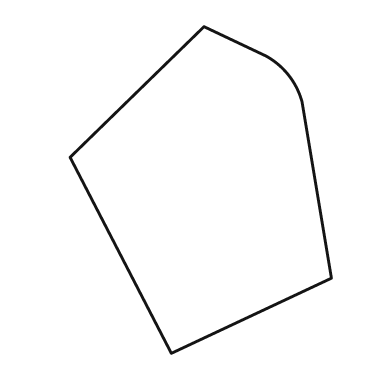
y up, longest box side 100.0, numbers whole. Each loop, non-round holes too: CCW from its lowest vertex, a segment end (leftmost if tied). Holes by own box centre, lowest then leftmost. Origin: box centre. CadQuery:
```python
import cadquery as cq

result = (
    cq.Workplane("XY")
    .moveTo(-9.0, -50.0)
    .lineTo(40.0, -27.0)
    .lineTo(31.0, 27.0)
    .threePointArc((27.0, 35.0), (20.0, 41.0))
    .lineTo(1.0, 50.0)
    .lineTo(-40.0, 10.0)
    .close()
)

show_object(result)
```